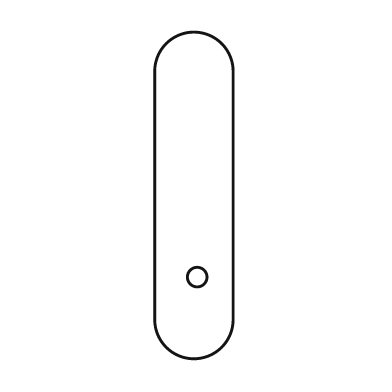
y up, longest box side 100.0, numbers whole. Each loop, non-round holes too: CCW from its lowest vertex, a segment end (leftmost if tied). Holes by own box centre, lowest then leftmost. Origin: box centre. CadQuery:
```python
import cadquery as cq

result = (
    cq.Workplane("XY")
    .moveTo(-12.0, -38.0)
    .threePointArc((0.0, -50.0), (12.0, -38.0))
    .lineTo(12.0, 38.0)
    .threePointArc((0.0, 50.0), (-12.0, 38.0))
    .close()
    .moveTo(1.0, -25.0)
    .circle(3.0)
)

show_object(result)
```